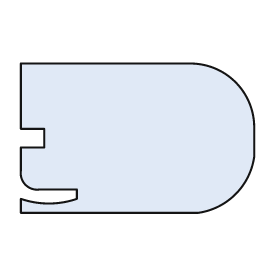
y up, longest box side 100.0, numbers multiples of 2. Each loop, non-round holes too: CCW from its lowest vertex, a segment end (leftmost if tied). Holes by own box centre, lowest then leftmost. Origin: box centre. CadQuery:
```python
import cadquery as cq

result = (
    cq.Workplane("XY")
    .moveTo(-50.0, -32.0)
    .lineTo(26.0, -32.0)
    .threePointArc((42.0, -24.0), (50.0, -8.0))
    .lineTo(50.0, 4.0)
    .threePointArc((42.0, 24.0), (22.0, 32.0))
    .lineTo(-50.0, 32.0)
    .lineTo(-50.0, 4.0)
    .lineTo(-40.0, 4.0)
    .lineTo(-40.0, -4.0)
    .lineTo(-50.0, -4.0)
    .lineTo(-50.0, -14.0)
    .threePointArc((-48.0, -20.0), (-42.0, -22.0))
    .lineTo(-26.0, -22.0)
    .lineTo(-26.0, -26.0)
    .threePointArc((-38.0, -28.0), (-50.0, -26.0))
    .close()
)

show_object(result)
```